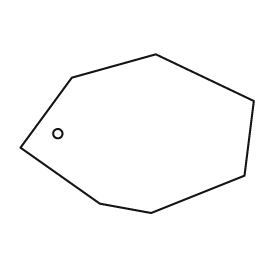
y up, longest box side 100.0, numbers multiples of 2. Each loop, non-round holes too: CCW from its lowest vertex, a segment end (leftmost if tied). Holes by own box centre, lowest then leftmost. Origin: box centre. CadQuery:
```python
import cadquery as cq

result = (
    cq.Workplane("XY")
    .moveTo(6.0, -34.0)
    .lineTo(46.0, -18.0)
    .lineTo(50.0, 14.0)
    .lineTo(8.0, 34.0)
    .lineTo(-28.0, 24.0)
    .lineTo(-50.0, -6.0)
    .lineTo(-16.0, -30.0)
    .close()
    .moveTo(-34.0, 0.0)
    .circle(2.0)
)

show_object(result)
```